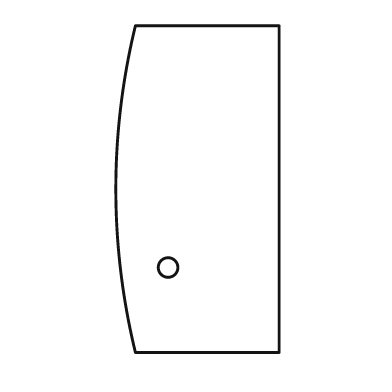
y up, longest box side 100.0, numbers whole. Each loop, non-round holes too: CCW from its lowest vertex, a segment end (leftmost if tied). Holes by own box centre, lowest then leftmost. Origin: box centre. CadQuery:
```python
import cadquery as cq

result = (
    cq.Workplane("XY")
    .moveTo(-19.0, -50.0)
    .lineTo(25.0, -50.0)
    .lineTo(25.0, 50.0)
    .lineTo(-19.0, 50.0)
    .threePointArc((-25.0, 0.0), (-19.0, -50.0))
    .close()
    .moveTo(-9.0, -24.0)
    .circle(3.0)
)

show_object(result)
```